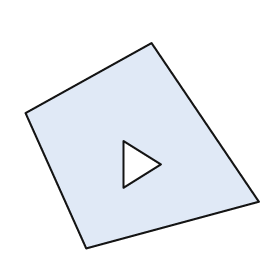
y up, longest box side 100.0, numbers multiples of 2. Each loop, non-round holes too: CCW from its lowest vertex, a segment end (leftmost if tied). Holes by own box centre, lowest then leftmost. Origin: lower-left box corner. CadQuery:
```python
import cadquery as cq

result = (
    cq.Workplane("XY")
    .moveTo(26.0, 0.0)
    .lineTo(100.0, 20.0)
    .lineTo(54.0, 88.0)
    .lineTo(0.0, 58.0)
    .close()
    .moveTo(42.0, 26.0)
    .lineTo(58.0, 36.0)
    .lineTo(42.0, 46.0)
    .close()
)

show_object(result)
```